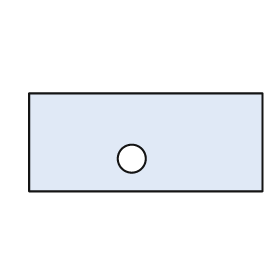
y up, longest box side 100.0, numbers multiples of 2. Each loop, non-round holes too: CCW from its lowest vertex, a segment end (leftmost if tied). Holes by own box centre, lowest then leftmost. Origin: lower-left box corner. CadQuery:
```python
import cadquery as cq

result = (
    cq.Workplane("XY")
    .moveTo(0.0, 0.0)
    .lineTo(100.0, 0.0)
    .lineTo(100.0, 42.0)
    .lineTo(0.0, 42.0)
    .close()
    .moveTo(44.0, 14.0)
    .circle(6.0)
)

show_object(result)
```